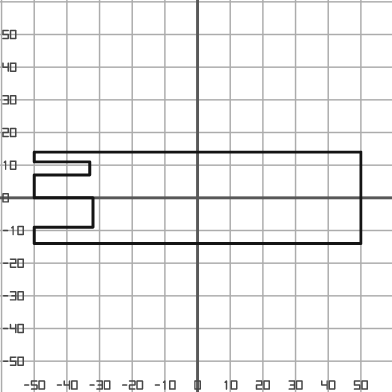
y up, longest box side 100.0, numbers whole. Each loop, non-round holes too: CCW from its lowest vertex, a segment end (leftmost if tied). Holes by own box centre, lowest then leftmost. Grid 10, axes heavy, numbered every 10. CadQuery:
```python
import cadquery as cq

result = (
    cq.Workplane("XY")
    .moveTo(-50.0, -14.0)
    .lineTo(50.0, -14.0)
    .lineTo(50.0, 14.0)
    .lineTo(-50.0, 14.0)
    .lineTo(-50.0, 11.0)
    .lineTo(-33.0, 11.0)
    .lineTo(-33.0, 7.0)
    .lineTo(-50.0, 7.0)
    .lineTo(-50.0, 0.0)
    .lineTo(-32.0, 0.0)
    .lineTo(-32.0, -9.0)
    .lineTo(-50.0, -9.0)
    .close()
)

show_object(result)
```